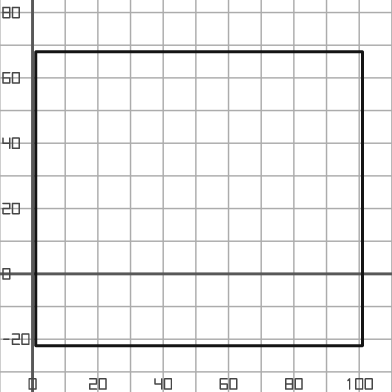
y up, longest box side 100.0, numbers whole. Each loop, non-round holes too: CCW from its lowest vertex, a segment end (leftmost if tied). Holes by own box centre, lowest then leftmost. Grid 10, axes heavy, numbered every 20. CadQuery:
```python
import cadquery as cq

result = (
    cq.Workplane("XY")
    .moveTo(1.0, -22.0)
    .lineTo(101.0, -22.0)
    .lineTo(101.0, 68.0)
    .lineTo(1.0, 68.0)
    .close()
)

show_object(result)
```